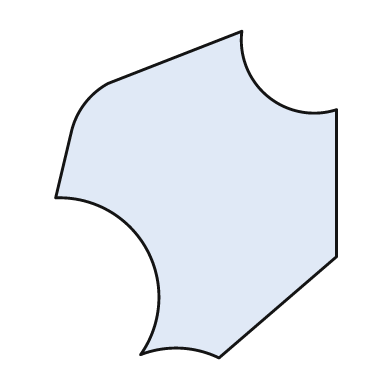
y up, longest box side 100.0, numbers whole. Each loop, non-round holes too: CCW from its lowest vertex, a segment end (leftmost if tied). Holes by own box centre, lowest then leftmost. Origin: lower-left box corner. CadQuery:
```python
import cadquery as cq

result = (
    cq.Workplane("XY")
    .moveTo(50.0, 0.0)
    .lineTo(86.0, 31.0)
    .lineTo(86.0, 76.0)
    .threePointArc((65.0, 80.0), (57.0, 100.0))
    .lineTo(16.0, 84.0)
    .threePointArc((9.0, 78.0), (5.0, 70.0))
    .lineTo(0.0, 49.0)
    .threePointArc((28.0, 33.0), (26.0, 1.0))
    .threePointArc((38.0, 3.0), (50.0, 0.0))
    .close()
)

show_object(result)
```